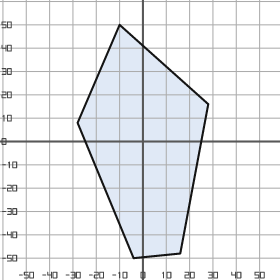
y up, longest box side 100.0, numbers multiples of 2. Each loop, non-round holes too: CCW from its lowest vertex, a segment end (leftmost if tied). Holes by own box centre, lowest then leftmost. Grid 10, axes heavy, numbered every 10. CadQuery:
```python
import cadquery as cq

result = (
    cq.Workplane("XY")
    .moveTo(-4.0, -50.0)
    .lineTo(16.0, -48.0)
    .lineTo(28.0, 16.0)
    .lineTo(-10.0, 50.0)
    .lineTo(-28.0, 8.0)
    .close()
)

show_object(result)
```